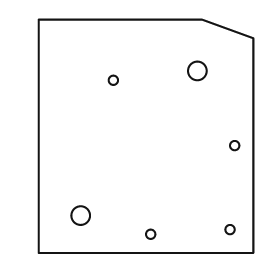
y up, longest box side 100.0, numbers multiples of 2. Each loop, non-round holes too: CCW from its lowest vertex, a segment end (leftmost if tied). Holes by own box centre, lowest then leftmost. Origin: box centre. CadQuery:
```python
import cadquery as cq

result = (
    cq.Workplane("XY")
    .moveTo(-46.0, -50.0)
    .lineTo(46.0, -50.0)
    .lineTo(46.0, 42.0)
    .lineTo(24.0, 50.0)
    .lineTo(-46.0, 50.0)
    .close()
    .moveTo(2.0, -42.0)
    .circle(2.0)
    .moveTo(36.0, -40.0)
    .circle(2.0)
    .moveTo(-28.0, -34.0)
    .circle(4.0)
    .moveTo(38.0, -4.0)
    .circle(2.0)
    .moveTo(-14.0, 24.0)
    .circle(2.0)
    .moveTo(22.0, 28.0)
    .circle(4.0)
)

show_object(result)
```